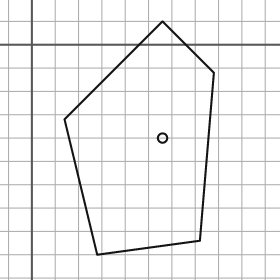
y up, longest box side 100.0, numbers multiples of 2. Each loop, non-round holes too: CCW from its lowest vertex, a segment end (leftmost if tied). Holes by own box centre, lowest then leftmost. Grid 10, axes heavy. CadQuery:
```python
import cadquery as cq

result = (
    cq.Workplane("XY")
    .moveTo(28.0, -90.0)
    .lineTo(72.0, -84.0)
    .lineTo(78.0, -12.0)
    .lineTo(56.0, 10.0)
    .lineTo(14.0, -32.0)
    .close()
    .moveTo(56.0, -40.0)
    .circle(2.0)
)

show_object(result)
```